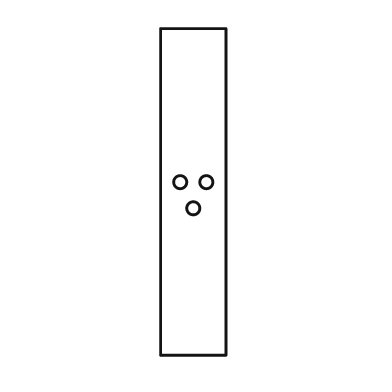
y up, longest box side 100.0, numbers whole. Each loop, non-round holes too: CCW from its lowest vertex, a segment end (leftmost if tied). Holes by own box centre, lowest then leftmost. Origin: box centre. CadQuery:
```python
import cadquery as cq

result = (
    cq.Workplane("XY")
    .moveTo(-10.0, -50.0)
    .lineTo(10.0, -50.0)
    .lineTo(10.0, 50.0)
    .lineTo(-10.0, 50.0)
    .close()
    .moveTo(0.0, -5.0)
    .circle(2.0)
    .moveTo(-4.0, 3.0)
    .circle(2.0)
    .moveTo(4.0, 3.0)
    .circle(2.0)
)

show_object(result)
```